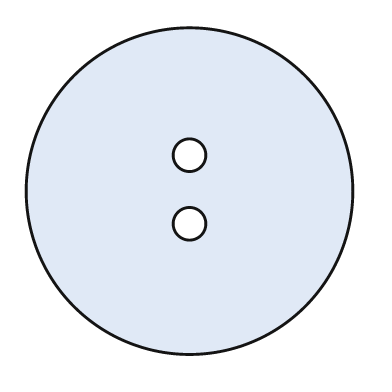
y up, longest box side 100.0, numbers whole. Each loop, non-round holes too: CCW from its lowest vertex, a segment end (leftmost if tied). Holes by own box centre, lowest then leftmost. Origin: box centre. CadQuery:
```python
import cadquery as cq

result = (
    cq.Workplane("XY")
    .moveTo(0.0, 0.0)
    .circle(50.0)
    .moveTo(0.0, -10.0)
    .circle(5.0)
    .moveTo(0.0, 11.0)
    .circle(5.0)
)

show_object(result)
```